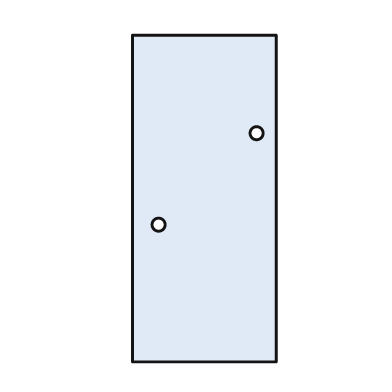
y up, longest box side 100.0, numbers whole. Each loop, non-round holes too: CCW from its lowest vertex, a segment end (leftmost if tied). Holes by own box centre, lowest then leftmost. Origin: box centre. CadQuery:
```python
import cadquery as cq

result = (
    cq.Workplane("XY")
    .moveTo(-22.0, -50.0)
    .lineTo(22.0, -50.0)
    .lineTo(22.0, 50.0)
    .lineTo(-22.0, 50.0)
    .close()
    .moveTo(-14.0, -8.0)
    .circle(2.0)
    .moveTo(16.0, 20.0)
    .circle(2.0)
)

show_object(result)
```